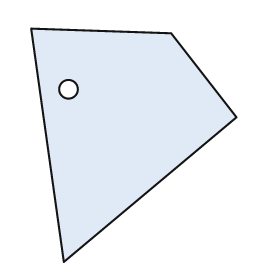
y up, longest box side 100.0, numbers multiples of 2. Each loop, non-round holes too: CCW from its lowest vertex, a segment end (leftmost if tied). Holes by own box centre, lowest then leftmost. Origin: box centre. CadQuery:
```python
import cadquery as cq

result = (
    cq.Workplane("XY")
    .moveTo(-30.0, -50.0)
    .lineTo(44.0, 12.0)
    .lineTo(16.0, 48.0)
    .lineTo(-44.0, 50.0)
    .close()
    .moveTo(-28.0, 24.0)
    .circle(4.0)
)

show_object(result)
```